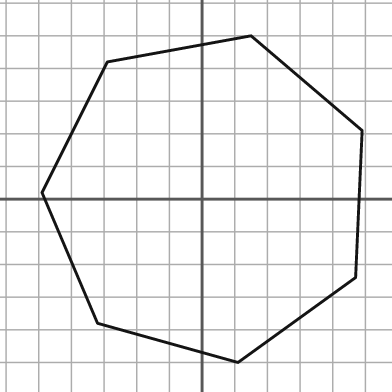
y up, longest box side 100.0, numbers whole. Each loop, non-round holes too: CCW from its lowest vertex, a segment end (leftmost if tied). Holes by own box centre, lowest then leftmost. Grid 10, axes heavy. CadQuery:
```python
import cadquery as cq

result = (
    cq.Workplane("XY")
    .moveTo(11.0, -50.0)
    .lineTo(47.0, -24.0)
    .lineTo(49.0, 21.0)
    .lineTo(15.0, 50.0)
    .lineTo(-29.0, 42.0)
    .lineTo(-49.0, 2.0)
    .lineTo(-32.0, -38.0)
    .close()
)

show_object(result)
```